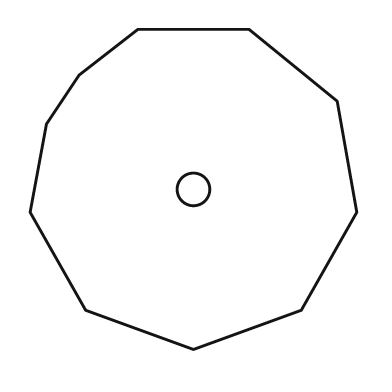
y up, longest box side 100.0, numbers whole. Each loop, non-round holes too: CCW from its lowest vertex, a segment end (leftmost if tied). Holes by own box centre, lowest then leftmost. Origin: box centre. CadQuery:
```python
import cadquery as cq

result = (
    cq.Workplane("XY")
    .moveTo(0.0, -49.0)
    .lineTo(33.0, -37.0)
    .lineTo(50.0, -7.0)
    .lineTo(44.0, 27.0)
    .lineTo(17.0, 49.0)
    .lineTo(-17.0, 49.0)
    .lineTo(-35.0, 35.0)
    .lineTo(-45.0, 20.0)
    .lineTo(-50.0, -7.0)
    .lineTo(-33.0, -37.0)
    .close()
    .moveTo(0.0, 0.0)
    .circle(5.0)
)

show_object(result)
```